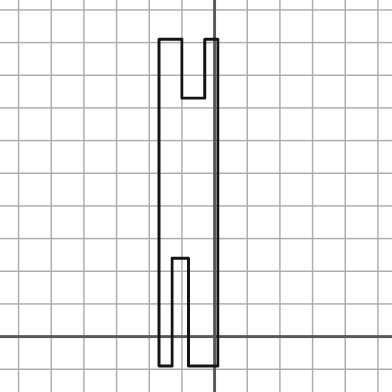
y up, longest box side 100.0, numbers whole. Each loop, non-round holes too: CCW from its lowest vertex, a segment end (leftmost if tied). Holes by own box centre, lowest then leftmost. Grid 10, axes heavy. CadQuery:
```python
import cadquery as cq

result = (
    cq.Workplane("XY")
    .moveTo(-17.0, -9.0)
    .lineTo(-13.0, -9.0)
    .lineTo(-13.0, 24.0)
    .lineTo(-8.0, 24.0)
    .lineTo(-8.0, -9.0)
    .lineTo(1.0, -9.0)
    .lineTo(1.0, 91.0)
    .lineTo(-3.0, 91.0)
    .lineTo(-3.0, 73.0)
    .lineTo(-10.0, 73.0)
    .lineTo(-10.0, 91.0)
    .lineTo(-17.0, 91.0)
    .close()
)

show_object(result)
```